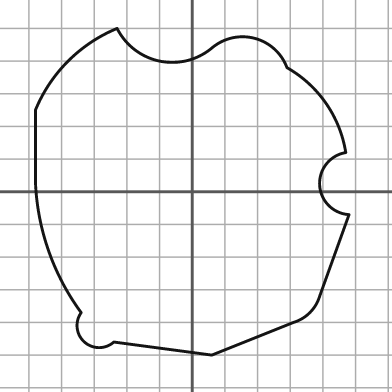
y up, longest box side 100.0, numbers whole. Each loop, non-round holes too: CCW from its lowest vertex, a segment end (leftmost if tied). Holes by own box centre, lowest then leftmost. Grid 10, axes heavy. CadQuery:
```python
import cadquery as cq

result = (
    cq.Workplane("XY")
    .moveTo(6.0, -50.0)
    .lineTo(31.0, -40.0)
    .threePointArc((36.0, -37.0), (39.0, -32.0))
    .lineTo(48.0, -7.0)
    .threePointArc((39.0, 2.0), (47.0, 12.0))
    .threePointArc((41.0, 27.0), (29.0, 38.0))
    .threePointArc((19.0, 47.0), (6.0, 44.0))
    .threePointArc((-10.0, 40.0), (-23.0, 50.0))
    .threePointArc((-38.0, 40.0), (-48.0, 25.0))
    .lineTo(-48.0, 3.0)
    .threePointArc((-44.0, -18.0), (-34.0, -37.0))
    .threePointArc((-33.0, -46.0), (-24.0, -46.0))
    .close()
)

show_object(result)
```